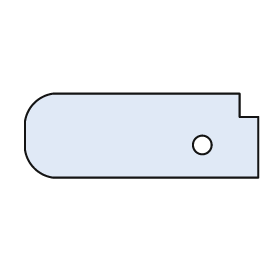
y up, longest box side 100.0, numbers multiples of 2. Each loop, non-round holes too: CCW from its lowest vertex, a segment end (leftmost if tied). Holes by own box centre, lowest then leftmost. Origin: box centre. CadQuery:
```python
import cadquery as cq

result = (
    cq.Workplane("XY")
    .moveTo(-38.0, -18.0)
    .lineTo(50.0, -18.0)
    .lineTo(50.0, 8.0)
    .lineTo(42.0, 8.0)
    .lineTo(42.0, 18.0)
    .lineTo(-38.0, 18.0)
    .threePointArc((-46.0, 14.0), (-50.0, 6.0))
    .lineTo(-50.0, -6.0)
    .threePointArc((-46.0, -14.0), (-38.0, -18.0))
    .close()
    .moveTo(26.0, -4.0)
    .circle(4.0)
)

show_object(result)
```